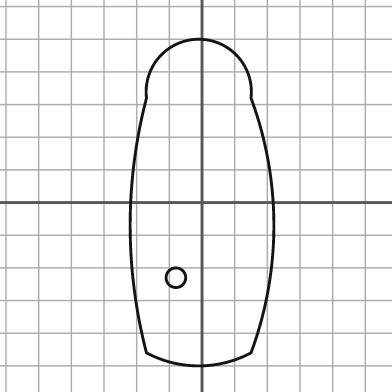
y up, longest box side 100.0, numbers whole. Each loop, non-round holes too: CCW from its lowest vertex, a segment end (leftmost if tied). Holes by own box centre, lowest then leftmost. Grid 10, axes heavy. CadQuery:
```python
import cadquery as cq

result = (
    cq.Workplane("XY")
    .moveTo(-17.0, -46.0)
    .threePointArc((-1.0, -50.0), (15.0, -46.0))
    .threePointArc((22.0, -7.0), (15.0, 32.0))
    .threePointArc((-1.0, 50.0), (-17.0, 32.0))
    .threePointArc((-22.0, -7.0), (-17.0, -46.0))
    .close()
    .moveTo(-8.0, -23.0)
    .circle(3.0)
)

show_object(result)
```